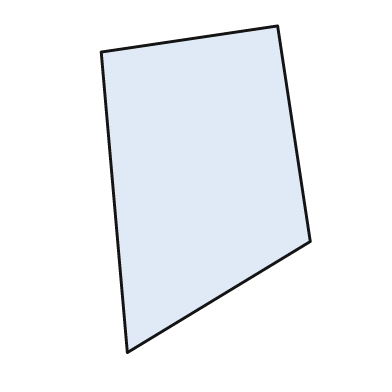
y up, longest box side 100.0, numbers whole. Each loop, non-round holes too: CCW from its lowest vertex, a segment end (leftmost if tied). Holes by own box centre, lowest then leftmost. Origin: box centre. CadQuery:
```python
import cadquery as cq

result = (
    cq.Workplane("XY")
    .moveTo(-24.0, -50.0)
    .lineTo(32.0, -16.0)
    .lineTo(22.0, 50.0)
    .lineTo(-32.0, 42.0)
    .close()
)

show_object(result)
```